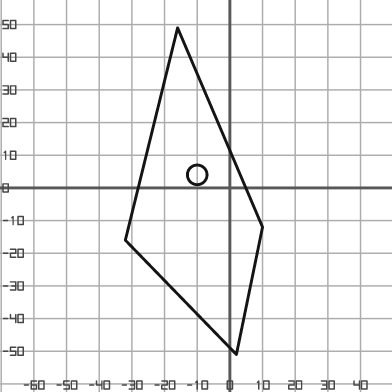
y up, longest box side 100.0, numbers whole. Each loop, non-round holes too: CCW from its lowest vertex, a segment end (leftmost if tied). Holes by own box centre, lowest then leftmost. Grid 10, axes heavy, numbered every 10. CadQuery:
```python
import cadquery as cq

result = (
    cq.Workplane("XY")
    .moveTo(2.0, -51.0)
    .lineTo(10.0, -12.0)
    .lineTo(-16.0, 49.0)
    .lineTo(-32.0, -16.0)
    .close()
    .moveTo(-10.0, 4.0)
    .circle(3.0)
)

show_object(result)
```